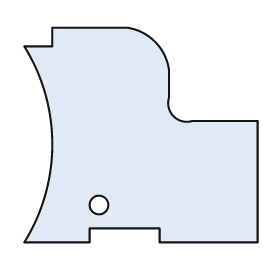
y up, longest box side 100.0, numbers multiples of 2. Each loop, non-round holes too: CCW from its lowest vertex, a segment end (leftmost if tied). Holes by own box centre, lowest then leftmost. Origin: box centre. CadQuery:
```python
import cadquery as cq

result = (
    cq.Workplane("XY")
    .moveTo(-50.0, -46.0)
    .lineTo(-22.0, -46.0)
    .lineTo(-22.0, -40.0)
    .lineTo(8.0, -40.0)
    .lineTo(8.0, -46.0)
    .lineTo(50.0, -46.0)
    .lineTo(50.0, 6.0)
    .lineTo(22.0, 6.0)
    .threePointArc((14.0, 8.0), (12.0, 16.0))
    .lineTo(12.0, 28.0)
    .threePointArc((6.0, 40.0), (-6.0, 46.0))
    .lineTo(-38.0, 46.0)
    .lineTo(-38.0, 38.0)
    .lineTo(-50.0, 38.0)
    .threePointArc((-38.0, -4.0), (-50.0, -46.0))
    .close()
    .moveTo(-18.0, -30.0)
    .circle(4.0)
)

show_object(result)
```